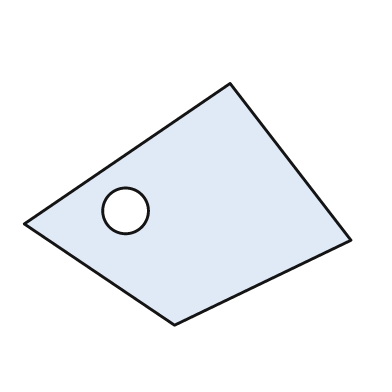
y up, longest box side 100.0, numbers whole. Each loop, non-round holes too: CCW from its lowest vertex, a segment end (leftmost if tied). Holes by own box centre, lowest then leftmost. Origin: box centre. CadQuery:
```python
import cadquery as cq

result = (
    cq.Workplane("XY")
    .moveTo(-4.0, -37.0)
    .lineTo(50.0, -11.0)
    .lineTo(13.0, 37.0)
    .lineTo(-50.0, -6.0)
    .close()
    .moveTo(-19.0, -2.0)
    .circle(7.0)
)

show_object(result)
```